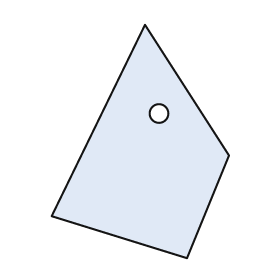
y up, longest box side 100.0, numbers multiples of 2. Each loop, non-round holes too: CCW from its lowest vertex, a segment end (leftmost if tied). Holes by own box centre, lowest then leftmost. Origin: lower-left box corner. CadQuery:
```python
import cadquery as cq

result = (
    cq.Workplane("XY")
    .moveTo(58.0, 0.0)
    .lineTo(76.0, 44.0)
    .lineTo(40.0, 100.0)
    .lineTo(0.0, 18.0)
    .close()
    .moveTo(46.0, 62.0)
    .circle(4.0)
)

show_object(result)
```